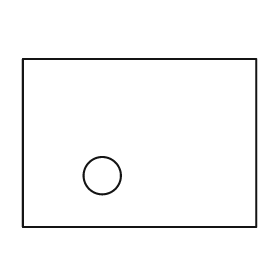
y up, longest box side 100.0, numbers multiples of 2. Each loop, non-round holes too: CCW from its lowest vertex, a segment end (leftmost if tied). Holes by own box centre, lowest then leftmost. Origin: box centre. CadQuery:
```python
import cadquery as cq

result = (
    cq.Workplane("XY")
    .moveTo(-50.0, -36.0)
    .lineTo(50.0, -36.0)
    .lineTo(50.0, 36.0)
    .lineTo(-50.0, 36.0)
    .close()
    .moveTo(-16.0, -14.0)
    .circle(8.0)
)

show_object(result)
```